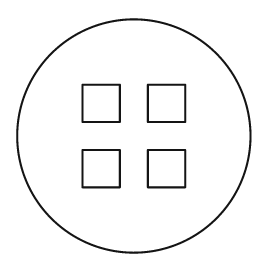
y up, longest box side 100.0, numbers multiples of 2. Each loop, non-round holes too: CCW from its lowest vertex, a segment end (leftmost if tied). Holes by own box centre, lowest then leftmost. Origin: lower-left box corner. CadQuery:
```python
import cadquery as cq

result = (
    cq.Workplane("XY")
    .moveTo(50.0, 50.0)
    .circle(50.0)
    .moveTo(28.0, 28.0)
    .lineTo(44.0, 28.0)
    .lineTo(44.0, 44.0)
    .lineTo(28.0, 44.0)
    .close()
    .moveTo(56.0, 28.0)
    .lineTo(72.0, 28.0)
    .lineTo(72.0, 44.0)
    .lineTo(56.0, 44.0)
    .close()
    .moveTo(28.0, 56.0)
    .lineTo(44.0, 56.0)
    .lineTo(44.0, 72.0)
    .lineTo(28.0, 72.0)
    .close()
    .moveTo(56.0, 56.0)
    .lineTo(72.0, 56.0)
    .lineTo(72.0, 72.0)
    .lineTo(56.0, 72.0)
    .close()
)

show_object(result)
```